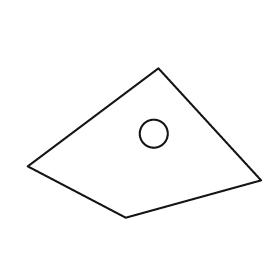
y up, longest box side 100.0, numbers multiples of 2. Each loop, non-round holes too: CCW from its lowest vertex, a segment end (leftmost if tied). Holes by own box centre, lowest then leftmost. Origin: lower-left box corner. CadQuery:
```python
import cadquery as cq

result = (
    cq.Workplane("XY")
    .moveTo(42.0, 0.0)
    .lineTo(100.0, 16.0)
    .lineTo(56.0, 64.0)
    .lineTo(0.0, 22.0)
    .close()
    .moveTo(54.0, 36.0)
    .circle(6.0)
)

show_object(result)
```